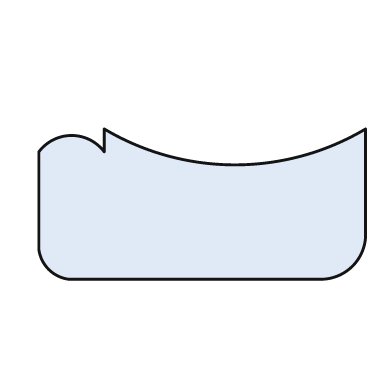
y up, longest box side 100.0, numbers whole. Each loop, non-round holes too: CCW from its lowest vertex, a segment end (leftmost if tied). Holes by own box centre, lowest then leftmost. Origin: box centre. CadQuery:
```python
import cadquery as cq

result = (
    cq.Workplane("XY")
    .moveTo(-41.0, -23.0)
    .lineTo(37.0, -23.0)
    .threePointArc((46.0, -19.0), (50.0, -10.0))
    .lineTo(50.0, 23.0)
    .threePointArc((10.0, 12.0), (-30.0, 23.0))
    .lineTo(-30.0, 16.0)
    .threePointArc((-40.0, 21.0), (-50.0, 16.0))
    .lineTo(-50.0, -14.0)
    .threePointArc((-47.0, -20.0), (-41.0, -23.0))
    .close()
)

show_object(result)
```